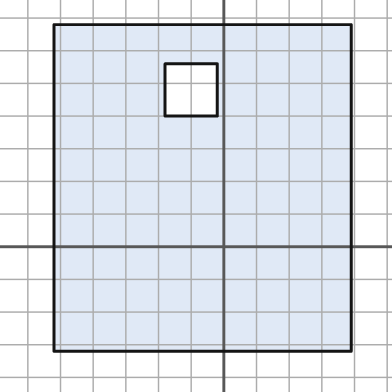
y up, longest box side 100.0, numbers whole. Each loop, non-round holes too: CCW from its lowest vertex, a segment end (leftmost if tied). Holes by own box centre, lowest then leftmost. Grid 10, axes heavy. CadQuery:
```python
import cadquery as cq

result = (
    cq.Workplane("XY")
    .moveTo(-52.0, -32.0)
    .lineTo(39.0, -32.0)
    .lineTo(39.0, 68.0)
    .lineTo(-52.0, 68.0)
    .close()
    .moveTo(-18.0, 40.0)
    .lineTo(-2.0, 40.0)
    .lineTo(-2.0, 56.0)
    .lineTo(-18.0, 56.0)
    .close()
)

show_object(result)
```